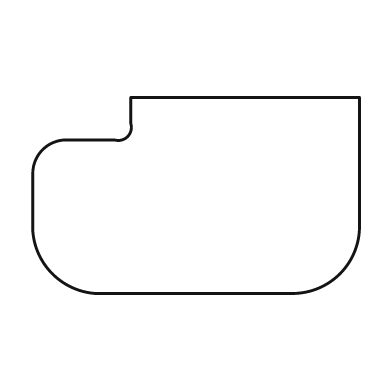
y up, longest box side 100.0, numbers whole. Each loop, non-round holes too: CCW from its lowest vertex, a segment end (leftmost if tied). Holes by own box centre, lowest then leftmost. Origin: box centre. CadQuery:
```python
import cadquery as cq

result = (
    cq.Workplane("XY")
    .moveTo(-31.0, -30.0)
    .lineTo(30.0, -30.0)
    .threePointArc((44.0, -24.0), (50.0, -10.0))
    .lineTo(50.0, 30.0)
    .lineTo(-20.0, 30.0)
    .lineTo(-20.0, 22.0)
    .threePointArc((-21.0, 18.0), (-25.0, 17.0))
    .lineTo(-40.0, 17.0)
    .threePointArc((-47.0, 14.0), (-50.0, 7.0))
    .lineTo(-50.0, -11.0)
    .threePointArc((-44.0, -24.0), (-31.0, -30.0))
    .close()
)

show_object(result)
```